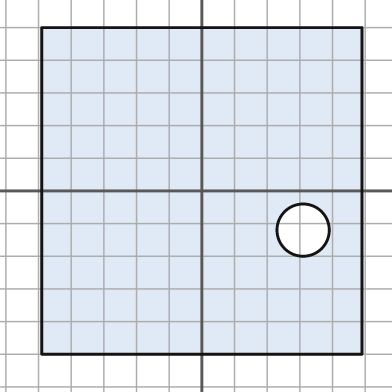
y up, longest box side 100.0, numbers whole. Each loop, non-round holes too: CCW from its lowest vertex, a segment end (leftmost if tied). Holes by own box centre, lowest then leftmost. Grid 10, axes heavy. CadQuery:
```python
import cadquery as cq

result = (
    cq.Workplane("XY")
    .moveTo(-49.0, -50.0)
    .lineTo(49.0, -50.0)
    .lineTo(49.0, 50.0)
    .lineTo(-49.0, 50.0)
    .close()
    .moveTo(31.0, -12.0)
    .circle(8.0)
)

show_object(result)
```